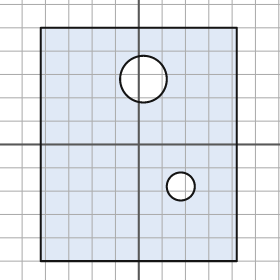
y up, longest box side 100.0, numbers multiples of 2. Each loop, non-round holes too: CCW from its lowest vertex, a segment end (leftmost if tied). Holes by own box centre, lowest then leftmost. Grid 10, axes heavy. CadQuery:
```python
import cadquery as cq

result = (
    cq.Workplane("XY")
    .moveTo(-42.0, -50.0)
    .lineTo(42.0, -50.0)
    .lineTo(42.0, 50.0)
    .lineTo(-42.0, 50.0)
    .close()
    .moveTo(18.0, -18.0)
    .circle(6.0)
    .moveTo(2.0, 28.0)
    .circle(10.0)
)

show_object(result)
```